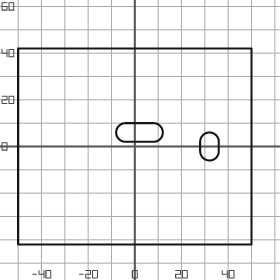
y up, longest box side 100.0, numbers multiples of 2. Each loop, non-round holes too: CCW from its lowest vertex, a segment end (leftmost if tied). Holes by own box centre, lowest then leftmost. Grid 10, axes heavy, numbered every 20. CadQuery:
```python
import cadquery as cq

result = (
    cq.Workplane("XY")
    .moveTo(-50.0, -42.0)
    .lineTo(50.0, -42.0)
    .lineTo(50.0, 42.0)
    .lineTo(-50.0, 42.0)
    .close()
    .moveTo(28.0, -2.0)
    .threePointArc((32.0, -6.0), (36.0, -2.0))
    .lineTo(36.0, 2.0)
    .threePointArc((32.0, 6.0), (28.0, 2.0))
    .close()
    .moveTo(-4.0, 2.0)
    .lineTo(8.0, 2.0)
    .threePointArc((12.0, 6.0), (8.0, 10.0))
    .lineTo(-4.0, 10.0)
    .threePointArc((-8.0, 6.0), (-4.0, 2.0))
    .close()
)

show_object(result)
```